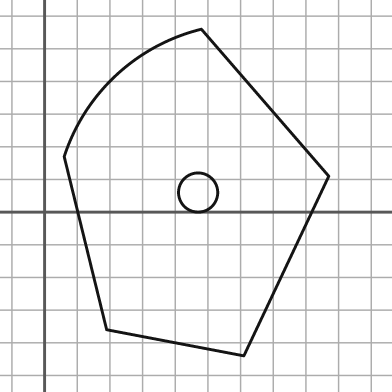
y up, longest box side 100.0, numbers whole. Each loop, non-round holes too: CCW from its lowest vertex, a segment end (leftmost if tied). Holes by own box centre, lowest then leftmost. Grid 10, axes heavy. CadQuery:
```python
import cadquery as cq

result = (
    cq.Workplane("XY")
    .moveTo(61.0, -44.0)
    .lineTo(87.0, 11.0)
    .lineTo(48.0, 56.0)
    .threePointArc((22.0, 42.0), (6.0, 17.0))
    .lineTo(19.0, -36.0)
    .close()
    .moveTo(47.0, 6.0)
    .circle(6.0)
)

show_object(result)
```